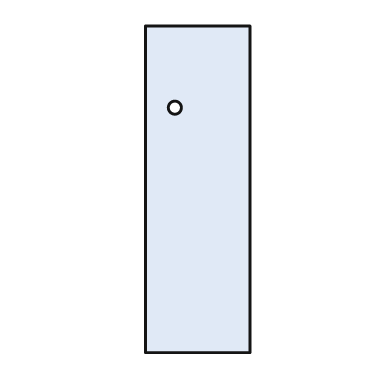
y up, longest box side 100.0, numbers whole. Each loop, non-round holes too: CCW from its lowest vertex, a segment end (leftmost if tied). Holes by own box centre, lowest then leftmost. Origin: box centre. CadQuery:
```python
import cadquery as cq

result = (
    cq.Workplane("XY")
    .moveTo(-16.0, -50.0)
    .lineTo(16.0, -50.0)
    .lineTo(16.0, 50.0)
    .lineTo(-16.0, 50.0)
    .close()
    .moveTo(-7.0, 25.0)
    .circle(2.0)
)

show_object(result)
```